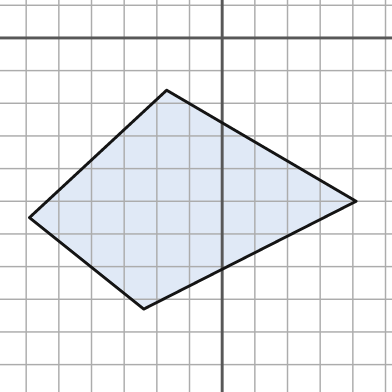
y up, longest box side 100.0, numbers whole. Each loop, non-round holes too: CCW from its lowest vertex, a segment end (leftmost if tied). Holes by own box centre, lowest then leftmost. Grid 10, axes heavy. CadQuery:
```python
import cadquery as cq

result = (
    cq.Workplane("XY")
    .moveTo(-24.0, -83.0)
    .lineTo(41.0, -50.0)
    .lineTo(-17.0, -16.0)
    .lineTo(-59.0, -55.0)
    .close()
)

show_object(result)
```